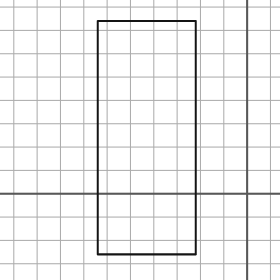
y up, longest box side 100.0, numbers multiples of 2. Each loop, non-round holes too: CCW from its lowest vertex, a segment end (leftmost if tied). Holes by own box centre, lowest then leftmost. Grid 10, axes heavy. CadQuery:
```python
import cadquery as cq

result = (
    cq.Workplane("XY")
    .moveTo(-64.0, -26.0)
    .lineTo(-22.0, -26.0)
    .lineTo(-22.0, 74.0)
    .lineTo(-64.0, 74.0)
    .close()
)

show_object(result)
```